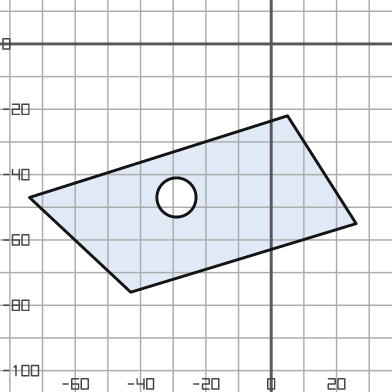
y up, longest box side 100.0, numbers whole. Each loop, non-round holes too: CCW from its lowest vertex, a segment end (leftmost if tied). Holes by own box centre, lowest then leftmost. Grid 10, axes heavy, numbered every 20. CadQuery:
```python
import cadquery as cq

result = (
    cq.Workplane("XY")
    .moveTo(-43.0, -76.0)
    .lineTo(26.0, -55.0)
    .lineTo(5.0, -22.0)
    .lineTo(-74.0, -47.0)
    .close()
    .moveTo(-29.0, -47.0)
    .circle(6.0)
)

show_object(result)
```